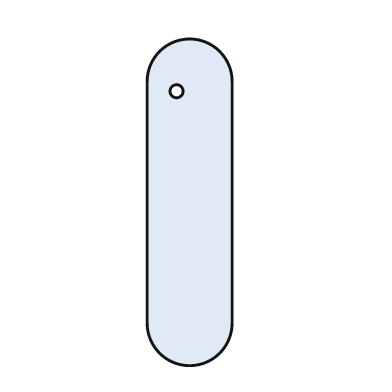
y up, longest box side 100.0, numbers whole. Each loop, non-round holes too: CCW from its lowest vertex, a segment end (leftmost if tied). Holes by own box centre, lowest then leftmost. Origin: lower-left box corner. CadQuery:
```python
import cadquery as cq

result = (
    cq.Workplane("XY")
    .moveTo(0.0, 13.0)
    .threePointArc((13.0, 0.0), (26.0, 13.0))
    .lineTo(26.0, 87.0)
    .threePointArc((13.0, 100.0), (0.0, 87.0))
    .close()
    .moveTo(9.0, 84.0)
    .circle(2.0)
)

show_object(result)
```